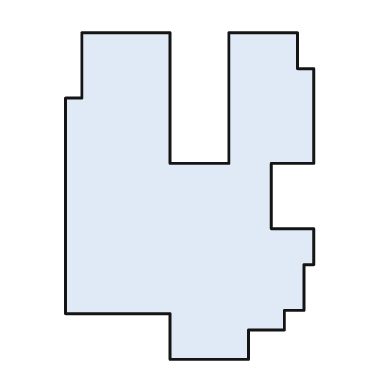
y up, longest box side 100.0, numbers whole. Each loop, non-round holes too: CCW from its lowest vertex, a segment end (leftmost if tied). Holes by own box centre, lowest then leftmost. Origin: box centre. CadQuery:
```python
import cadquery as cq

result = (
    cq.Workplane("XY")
    .moveTo(-6.0, -50.0)
    .lineTo(18.0, -50.0)
    .lineTo(18.0, -41.0)
    .lineTo(29.0, -41.0)
    .lineTo(29.0, -35.0)
    .lineTo(35.0, -35.0)
    .lineTo(35.0, -21.0)
    .lineTo(38.0, -21.0)
    .lineTo(38.0, -10.0)
    .lineTo(25.0, -10.0)
    .lineTo(25.0, 10.0)
    .lineTo(38.0, 10.0)
    .lineTo(38.0, 39.0)
    .lineTo(33.0, 39.0)
    .lineTo(33.0, 50.0)
    .lineTo(12.0, 50.0)
    .lineTo(12.0, 10.0)
    .lineTo(-6.0, 10.0)
    .lineTo(-6.0, 50.0)
    .lineTo(-33.0, 50.0)
    .lineTo(-33.0, 30.0)
    .lineTo(-38.0, 30.0)
    .lineTo(-38.0, -36.0)
    .lineTo(-6.0, -36.0)
    .close()
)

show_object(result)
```